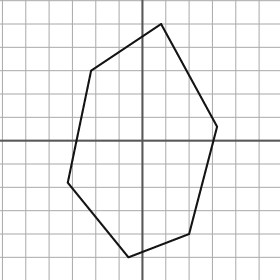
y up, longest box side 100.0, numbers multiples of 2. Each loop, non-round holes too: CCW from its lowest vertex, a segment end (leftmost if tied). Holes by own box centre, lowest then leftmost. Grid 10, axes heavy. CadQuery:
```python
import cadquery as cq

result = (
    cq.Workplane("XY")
    .moveTo(-6.0, -50.0)
    .lineTo(20.0, -40.0)
    .lineTo(32.0, 6.0)
    .lineTo(8.0, 50.0)
    .lineTo(-22.0, 30.0)
    .lineTo(-32.0, -18.0)
    .close()
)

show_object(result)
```